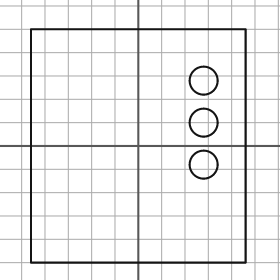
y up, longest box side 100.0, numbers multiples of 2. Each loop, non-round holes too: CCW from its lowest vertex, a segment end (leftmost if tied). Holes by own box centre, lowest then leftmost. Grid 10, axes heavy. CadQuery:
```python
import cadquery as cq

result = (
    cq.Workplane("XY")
    .moveTo(-46.0, -50.0)
    .lineTo(46.0, -50.0)
    .lineTo(46.0, 50.0)
    .lineTo(-46.0, 50.0)
    .close()
    .moveTo(28.0, -8.0)
    .circle(6.0)
    .moveTo(28.0, 10.0)
    .circle(6.0)
    .moveTo(28.0, 28.0)
    .circle(6.0)
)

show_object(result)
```